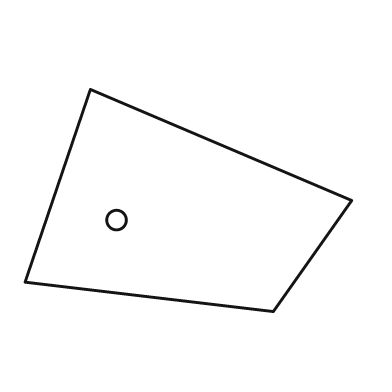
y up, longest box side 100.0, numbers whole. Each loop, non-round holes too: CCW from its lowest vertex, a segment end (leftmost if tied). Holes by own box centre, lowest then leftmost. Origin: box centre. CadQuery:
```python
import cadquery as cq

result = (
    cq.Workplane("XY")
    .moveTo(26.0, -34.0)
    .lineTo(50.0, 0.0)
    .lineTo(-30.0, 34.0)
    .lineTo(-50.0, -25.0)
    .close()
    .moveTo(-22.0, -6.0)
    .circle(3.0)
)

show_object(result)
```